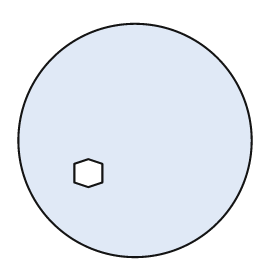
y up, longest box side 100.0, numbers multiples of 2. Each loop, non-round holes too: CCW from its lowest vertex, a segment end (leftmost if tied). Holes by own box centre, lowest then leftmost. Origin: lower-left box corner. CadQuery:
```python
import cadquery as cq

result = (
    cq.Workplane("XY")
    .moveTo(50.0, 50.0)
    .circle(50.0)
    .moveTo(30.0, 30.0)
    .lineTo(36.0, 32.0)
    .lineTo(36.0, 40.0)
    .lineTo(30.0, 42.0)
    .lineTo(24.0, 40.0)
    .lineTo(24.0, 32.0)
    .close()
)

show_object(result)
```